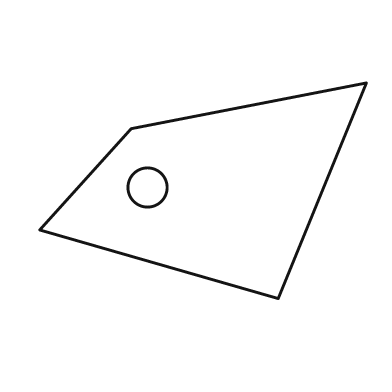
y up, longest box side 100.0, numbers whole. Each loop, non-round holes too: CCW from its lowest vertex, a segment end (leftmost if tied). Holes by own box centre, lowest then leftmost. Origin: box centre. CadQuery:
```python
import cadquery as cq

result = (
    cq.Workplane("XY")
    .moveTo(23.0, -33.0)
    .lineTo(50.0, 33.0)
    .lineTo(-22.0, 19.0)
    .lineTo(-50.0, -12.0)
    .close()
    .moveTo(-17.0, 1.0)
    .circle(6.0)
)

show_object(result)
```